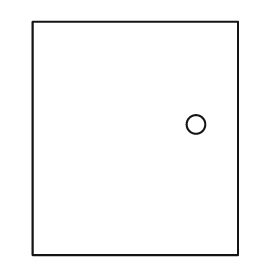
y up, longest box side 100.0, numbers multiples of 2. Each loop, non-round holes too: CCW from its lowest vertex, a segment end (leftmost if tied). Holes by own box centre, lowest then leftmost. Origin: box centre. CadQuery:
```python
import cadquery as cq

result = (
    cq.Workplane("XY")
    .moveTo(-44.0, -50.0)
    .lineTo(44.0, -50.0)
    .lineTo(44.0, 50.0)
    .lineTo(-44.0, 50.0)
    .close()
    .moveTo(26.0, 6.0)
    .circle(4.0)
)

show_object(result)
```